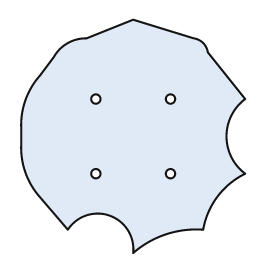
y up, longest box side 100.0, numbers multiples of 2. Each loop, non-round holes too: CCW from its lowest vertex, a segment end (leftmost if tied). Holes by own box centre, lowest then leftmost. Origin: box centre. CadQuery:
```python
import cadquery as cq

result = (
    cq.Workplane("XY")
    .moveTo(0.0, -50.0)
    .threePointArc((14.0, -42.0), (30.0, -40.0))
    .threePointArc((36.0, -26.0), (48.0, -16.0))
    .threePointArc((40.0, 0.0), (48.0, 16.0))
    .lineTo(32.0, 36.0)
    .threePointArc((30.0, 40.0), (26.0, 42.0))
    .lineTo(0.0, 50.0)
    .lineTo(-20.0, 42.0)
    .threePointArc((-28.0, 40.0), (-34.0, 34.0))
    .lineTo(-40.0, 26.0)
    .threePointArc((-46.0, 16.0), (-48.0, 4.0))
    .lineTo(-48.0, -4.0)
    .threePointArc((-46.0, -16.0), (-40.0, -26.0))
    .lineTo(-28.0, -40.0)
    .threePointArc((-10.0, -34.0), (0.0, -50.0))
    .close()
    .moveTo(-16.0, -16.0)
    .circle(2.0)
    .moveTo(16.0, -16.0)
    .circle(2.0)
    .moveTo(-16.0, 16.0)
    .circle(2.0)
    .moveTo(16.0, 16.0)
    .circle(2.0)
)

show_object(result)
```